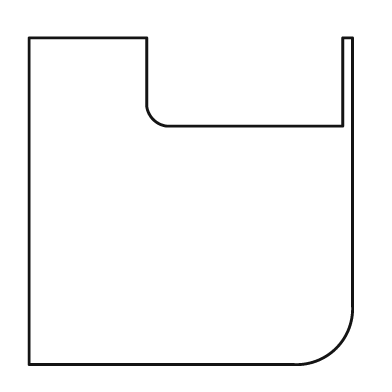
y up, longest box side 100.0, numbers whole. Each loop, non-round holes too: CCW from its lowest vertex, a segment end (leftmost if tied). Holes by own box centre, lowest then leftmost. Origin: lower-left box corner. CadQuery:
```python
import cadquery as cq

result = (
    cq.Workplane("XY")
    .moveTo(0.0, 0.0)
    .lineTo(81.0, 0.0)
    .threePointArc((94.0, 5.0), (99.0, 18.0))
    .lineTo(99.0, 100.0)
    .lineTo(96.0, 100.0)
    .lineTo(96.0, 73.0)
    .lineTo(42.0, 73.0)
    .threePointArc((38.0, 75.0), (36.0, 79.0))
    .lineTo(36.0, 100.0)
    .lineTo(0.0, 100.0)
    .close()
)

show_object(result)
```